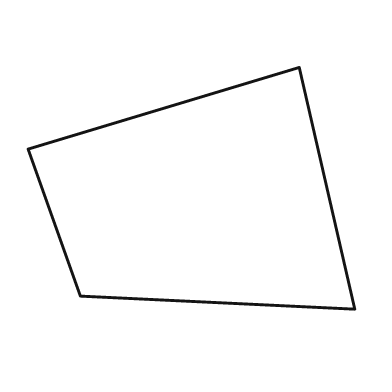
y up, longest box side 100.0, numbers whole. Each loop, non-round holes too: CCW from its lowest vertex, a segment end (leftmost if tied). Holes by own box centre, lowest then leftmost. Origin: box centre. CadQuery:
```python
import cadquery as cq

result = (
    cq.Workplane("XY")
    .moveTo(50.0, -37.0)
    .lineTo(33.0, 37.0)
    .lineTo(-50.0, 12.0)
    .lineTo(-34.0, -33.0)
    .close()
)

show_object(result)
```